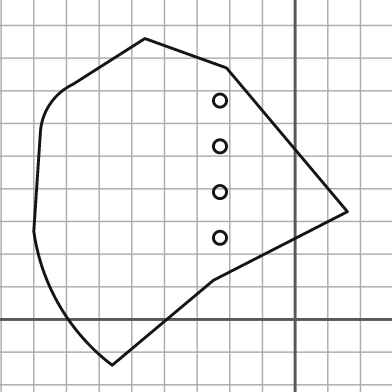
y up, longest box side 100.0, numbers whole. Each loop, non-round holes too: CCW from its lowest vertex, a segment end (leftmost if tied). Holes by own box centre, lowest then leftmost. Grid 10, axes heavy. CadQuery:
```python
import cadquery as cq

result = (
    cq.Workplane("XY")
    .moveTo(-56.0, -14.0)
    .lineTo(-25.0, 12.0)
    .lineTo(16.0, 33.0)
    .lineTo(-21.0, 77.0)
    .lineTo(-46.0, 86.0)
    .lineTo(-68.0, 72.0)
    .threePointArc((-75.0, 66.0), (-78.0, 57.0))
    .lineTo(-80.0, 27.0)
    .threePointArc((-72.0, 4.0), (-56.0, -14.0))
    .close()
    .moveTo(-23.0, 25.0)
    .circle(2.0)
    .moveTo(-23.0, 39.0)
    .circle(2.0)
    .moveTo(-23.0, 53.0)
    .circle(2.0)
    .moveTo(-23.0, 67.0)
    .circle(2.0)
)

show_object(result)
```